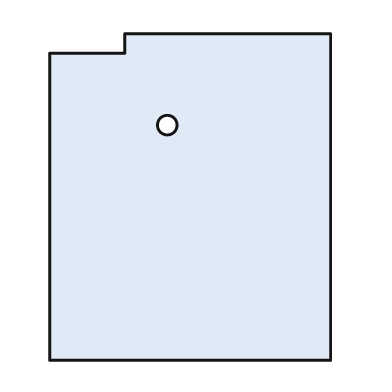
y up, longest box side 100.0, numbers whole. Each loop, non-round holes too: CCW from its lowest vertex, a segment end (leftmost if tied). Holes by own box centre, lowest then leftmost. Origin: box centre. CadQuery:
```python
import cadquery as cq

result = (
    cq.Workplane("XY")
    .moveTo(-43.0, -50.0)
    .lineTo(43.0, -50.0)
    .lineTo(43.0, 50.0)
    .lineTo(-20.0, 50.0)
    .lineTo(-20.0, 44.0)
    .lineTo(-43.0, 44.0)
    .close()
    .moveTo(-7.0, 22.0)
    .circle(3.0)
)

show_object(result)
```